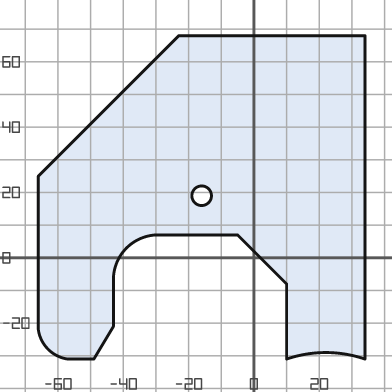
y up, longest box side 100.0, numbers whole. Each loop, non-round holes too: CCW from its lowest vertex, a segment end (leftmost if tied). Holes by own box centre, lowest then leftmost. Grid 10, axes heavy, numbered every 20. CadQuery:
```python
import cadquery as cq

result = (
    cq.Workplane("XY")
    .moveTo(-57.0, -31.0)
    .lineTo(-49.0, -31.0)
    .lineTo(-43.0, -21.0)
    .lineTo(-43.0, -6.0)
    .threePointArc((-39.0, 3.0), (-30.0, 7.0))
    .lineTo(-5.0, 7.0)
    .lineTo(10.0, -8.0)
    .lineTo(10.0, -31.0)
    .threePointArc((22.0, -29.0), (34.0, -31.0))
    .lineTo(34.0, 68.0)
    .lineTo(-23.0, 68.0)
    .lineTo(-66.0, 25.0)
    .lineTo(-66.0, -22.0)
    .threePointArc((-63.0, -28.0), (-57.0, -31.0))
    .close()
    .moveTo(-16.0, 19.0)
    .circle(3.0)
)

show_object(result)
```